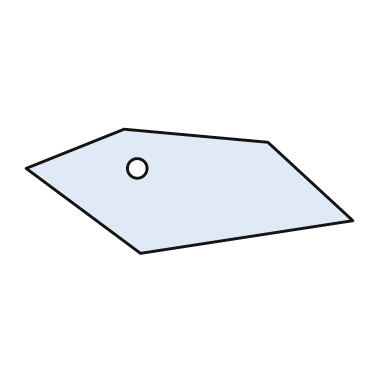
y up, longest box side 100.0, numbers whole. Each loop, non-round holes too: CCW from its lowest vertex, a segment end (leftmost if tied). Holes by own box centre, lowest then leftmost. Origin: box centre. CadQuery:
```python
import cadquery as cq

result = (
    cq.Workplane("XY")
    .moveTo(-15.0, -19.0)
    .lineTo(50.0, -9.0)
    .lineTo(24.0, 15.0)
    .lineTo(-20.0, 19.0)
    .lineTo(-50.0, 7.0)
    .close()
    .moveTo(-16.0, 7.0)
    .circle(3.0)
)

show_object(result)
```